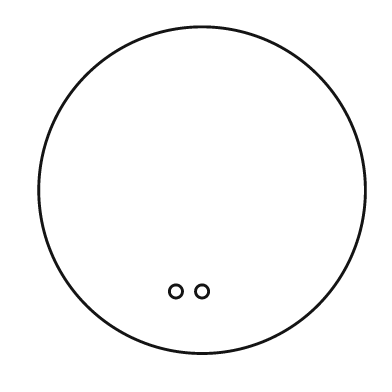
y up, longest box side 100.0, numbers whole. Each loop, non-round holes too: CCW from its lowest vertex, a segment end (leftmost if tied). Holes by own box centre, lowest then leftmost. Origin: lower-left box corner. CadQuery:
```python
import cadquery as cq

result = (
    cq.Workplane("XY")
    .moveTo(50.0, 50.0)
    .circle(50.0)
    .moveTo(42.0, 19.0)
    .circle(2.0)
    .moveTo(50.0, 19.0)
    .circle(2.0)
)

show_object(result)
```